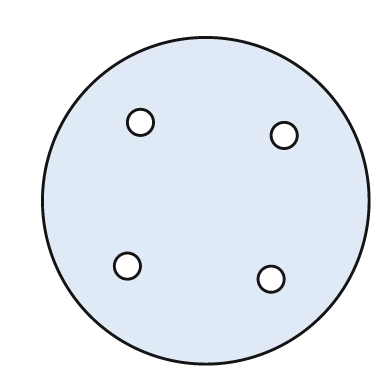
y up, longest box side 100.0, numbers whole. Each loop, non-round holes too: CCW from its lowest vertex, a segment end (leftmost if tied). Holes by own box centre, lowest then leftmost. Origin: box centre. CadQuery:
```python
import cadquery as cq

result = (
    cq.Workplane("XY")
    .moveTo(0.0, 0.0)
    .circle(50.0)
    .moveTo(20.0, -24.0)
    .circle(4.0)
    .moveTo(-24.0, -20.0)
    .circle(4.0)
    .moveTo(24.0, 20.0)
    .circle(4.0)
    .moveTo(-20.0, 24.0)
    .circle(4.0)
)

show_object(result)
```